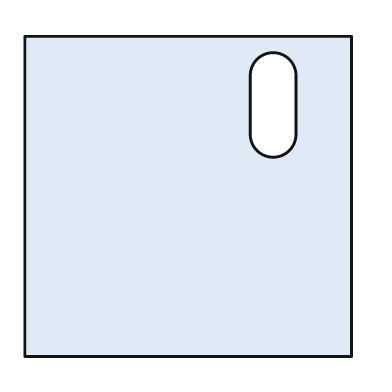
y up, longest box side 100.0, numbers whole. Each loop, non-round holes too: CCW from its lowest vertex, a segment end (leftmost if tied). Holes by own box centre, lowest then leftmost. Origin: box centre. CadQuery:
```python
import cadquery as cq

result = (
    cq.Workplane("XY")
    .moveTo(-50.0, -49.0)
    .lineTo(50.0, -49.0)
    .lineTo(50.0, 49.0)
    .lineTo(-50.0, 49.0)
    .close()
    .moveTo(19.0, 19.0)
    .threePointArc((26.0, 12.0), (33.0, 19.0))
    .lineTo(33.0, 37.0)
    .threePointArc((26.0, 44.0), (19.0, 37.0))
    .close()
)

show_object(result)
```